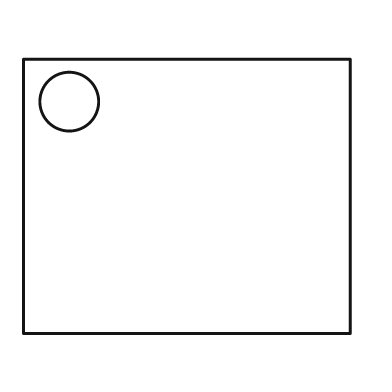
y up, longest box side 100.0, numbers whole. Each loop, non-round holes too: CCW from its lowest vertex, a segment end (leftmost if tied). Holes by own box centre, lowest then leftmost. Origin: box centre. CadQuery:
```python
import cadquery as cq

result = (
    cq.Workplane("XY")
    .moveTo(-50.0, -42.0)
    .lineTo(50.0, -42.0)
    .lineTo(50.0, 42.0)
    .lineTo(-50.0, 42.0)
    .close()
    .moveTo(-36.0, 29.0)
    .circle(9.0)
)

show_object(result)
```